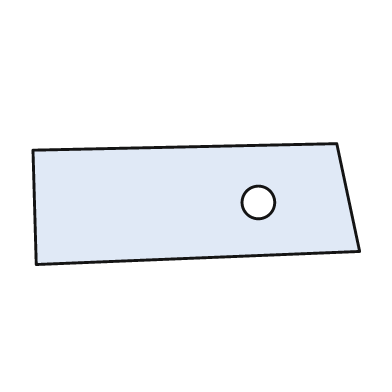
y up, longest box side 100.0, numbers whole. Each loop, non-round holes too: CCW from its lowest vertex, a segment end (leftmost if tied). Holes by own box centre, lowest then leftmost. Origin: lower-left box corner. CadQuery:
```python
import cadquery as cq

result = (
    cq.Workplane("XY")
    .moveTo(1.0, 0.0)
    .lineTo(100.0, 4.0)
    .lineTo(93.0, 37.0)
    .lineTo(0.0, 35.0)
    .close()
    .moveTo(69.0, 19.0)
    .circle(5.0)
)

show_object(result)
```